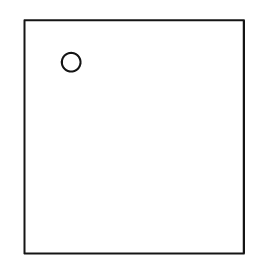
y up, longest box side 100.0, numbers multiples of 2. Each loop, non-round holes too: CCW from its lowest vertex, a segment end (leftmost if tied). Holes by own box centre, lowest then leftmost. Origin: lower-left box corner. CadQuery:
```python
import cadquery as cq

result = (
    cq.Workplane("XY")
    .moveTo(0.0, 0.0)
    .lineTo(94.0, 0.0)
    .lineTo(94.0, 100.0)
    .lineTo(0.0, 100.0)
    .close()
    .moveTo(20.0, 82.0)
    .circle(4.0)
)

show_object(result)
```